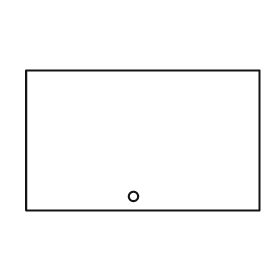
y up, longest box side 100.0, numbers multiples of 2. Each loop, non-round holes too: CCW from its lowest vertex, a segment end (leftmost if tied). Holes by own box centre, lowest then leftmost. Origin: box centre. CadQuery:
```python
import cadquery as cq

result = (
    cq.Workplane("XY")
    .moveTo(-50.0, -30.0)
    .lineTo(50.0, -30.0)
    .lineTo(50.0, 30.0)
    .lineTo(-50.0, 30.0)
    .close()
    .moveTo(-4.0, -24.0)
    .circle(2.0)
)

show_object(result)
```